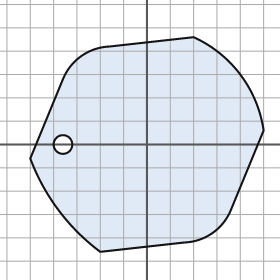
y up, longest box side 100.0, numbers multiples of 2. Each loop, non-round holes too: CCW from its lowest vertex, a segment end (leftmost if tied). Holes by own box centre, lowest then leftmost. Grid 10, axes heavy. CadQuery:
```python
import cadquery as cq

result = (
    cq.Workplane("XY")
    .moveTo(-20.0, -46.0)
    .lineTo(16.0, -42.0)
    .threePointArc((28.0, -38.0), (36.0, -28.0))
    .lineTo(50.0, 6.0)
    .threePointArc((40.0, 30.0), (20.0, 46.0))
    .lineTo(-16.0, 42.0)
    .threePointArc((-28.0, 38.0), (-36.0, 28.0))
    .lineTo(-50.0, -6.0)
    .threePointArc((-38.0, -28.0), (-20.0, -46.0))
    .close()
    .moveTo(-36.0, 0.0)
    .circle(4.0)
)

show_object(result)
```